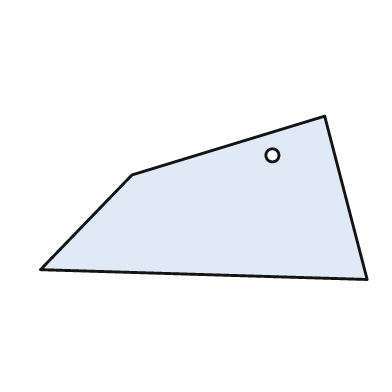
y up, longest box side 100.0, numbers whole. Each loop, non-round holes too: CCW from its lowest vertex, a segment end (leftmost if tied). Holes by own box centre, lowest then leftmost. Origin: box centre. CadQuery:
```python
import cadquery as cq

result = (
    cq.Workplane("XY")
    .moveTo(50.0, -25.0)
    .lineTo(37.0, 25.0)
    .lineTo(-22.0, 7.0)
    .lineTo(-50.0, -22.0)
    .close()
    .moveTo(21.0, 13.0)
    .circle(2.0)
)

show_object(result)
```